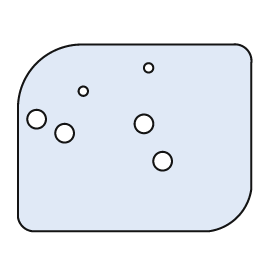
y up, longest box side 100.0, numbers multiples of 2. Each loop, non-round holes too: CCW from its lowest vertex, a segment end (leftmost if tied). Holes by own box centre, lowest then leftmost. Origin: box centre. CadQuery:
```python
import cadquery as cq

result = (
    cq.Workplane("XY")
    .moveTo(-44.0, -40.0)
    .lineTo(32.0, -40.0)
    .threePointArc((44.0, -34.0), (50.0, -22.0))
    .lineTo(50.0, 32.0)
    .threePointArc((48.0, 38.0), (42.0, 40.0))
    .lineTo(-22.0, 40.0)
    .threePointArc((-42.0, 32.0), (-50.0, 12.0))
    .lineTo(-50.0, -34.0)
    .threePointArc((-48.0, -38.0), (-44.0, -40.0))
    .close()
    .moveTo(12.0, -10.0)
    .circle(4.0)
    .moveTo(-30.0, 2.0)
    .circle(4.0)
    .moveTo(4.0, 6.0)
    .circle(4.0)
    .moveTo(-42.0, 8.0)
    .circle(4.0)
    .moveTo(-22.0, 20.0)
    .circle(2.0)
    .moveTo(6.0, 30.0)
    .circle(2.0)
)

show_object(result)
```